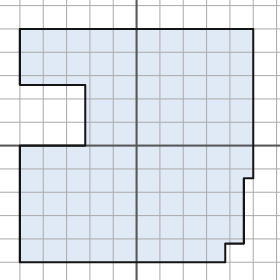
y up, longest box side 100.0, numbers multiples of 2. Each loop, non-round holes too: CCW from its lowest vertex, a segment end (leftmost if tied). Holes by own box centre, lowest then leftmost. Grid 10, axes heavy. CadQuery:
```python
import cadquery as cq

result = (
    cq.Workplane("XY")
    .moveTo(-50.0, -50.0)
    .lineTo(38.0, -50.0)
    .lineTo(38.0, -42.0)
    .lineTo(46.0, -42.0)
    .lineTo(46.0, -14.0)
    .lineTo(50.0, -14.0)
    .lineTo(50.0, 50.0)
    .lineTo(-50.0, 50.0)
    .lineTo(-50.0, 26.0)
    .lineTo(-22.0, 26.0)
    .lineTo(-22.0, 0.0)
    .lineTo(-50.0, 0.0)
    .close()
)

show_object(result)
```